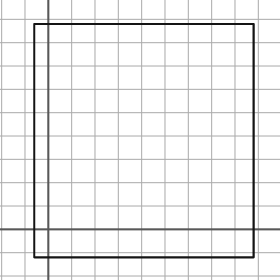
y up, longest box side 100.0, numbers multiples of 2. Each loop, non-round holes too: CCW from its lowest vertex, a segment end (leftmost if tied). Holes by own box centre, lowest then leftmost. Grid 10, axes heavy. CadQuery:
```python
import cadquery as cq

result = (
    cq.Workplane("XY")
    .moveTo(-6.0, -12.0)
    .lineTo(88.0, -12.0)
    .lineTo(88.0, 88.0)
    .lineTo(-6.0, 88.0)
    .close()
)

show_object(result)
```